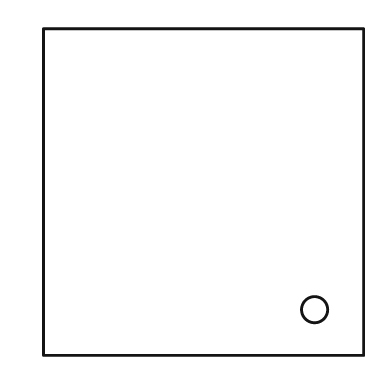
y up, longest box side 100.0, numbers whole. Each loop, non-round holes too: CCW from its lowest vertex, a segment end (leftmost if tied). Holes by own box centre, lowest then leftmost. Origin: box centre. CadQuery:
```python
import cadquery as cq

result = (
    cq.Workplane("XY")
    .moveTo(-49.0, -50.0)
    .lineTo(49.0, -50.0)
    .lineTo(49.0, 50.0)
    .lineTo(-49.0, 50.0)
    .close()
    .moveTo(34.0, -36.0)
    .circle(4.0)
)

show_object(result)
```